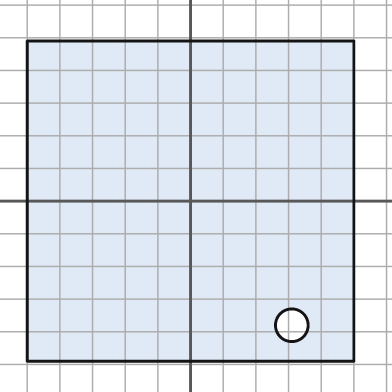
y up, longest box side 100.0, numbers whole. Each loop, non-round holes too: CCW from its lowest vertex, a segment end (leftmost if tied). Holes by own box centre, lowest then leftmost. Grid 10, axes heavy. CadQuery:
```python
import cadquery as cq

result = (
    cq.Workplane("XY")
    .moveTo(-50.0, -49.0)
    .lineTo(50.0, -49.0)
    .lineTo(50.0, 49.0)
    .lineTo(-50.0, 49.0)
    .close()
    .moveTo(31.0, -38.0)
    .circle(5.0)
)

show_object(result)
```